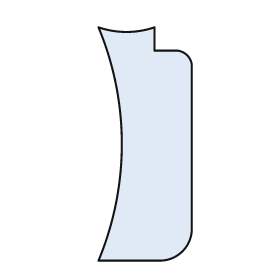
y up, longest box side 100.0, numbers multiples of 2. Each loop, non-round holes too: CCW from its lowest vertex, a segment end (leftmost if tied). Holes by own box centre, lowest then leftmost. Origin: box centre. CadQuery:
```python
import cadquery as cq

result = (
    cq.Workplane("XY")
    .moveTo(-20.0, -50.0)
    .lineTo(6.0, -50.0)
    .threePointArc((16.0, -46.0), (20.0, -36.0))
    .lineTo(20.0, 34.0)
    .threePointArc((18.0, 38.0), (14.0, 40.0))
    .lineTo(4.0, 40.0)
    .lineTo(4.0, 50.0)
    .threePointArc((-8.0, 48.0), (-20.0, 50.0))
    .threePointArc((-10.0, 0.0), (-20.0, -50.0))
    .close()
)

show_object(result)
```